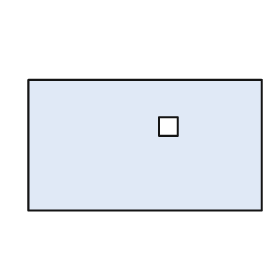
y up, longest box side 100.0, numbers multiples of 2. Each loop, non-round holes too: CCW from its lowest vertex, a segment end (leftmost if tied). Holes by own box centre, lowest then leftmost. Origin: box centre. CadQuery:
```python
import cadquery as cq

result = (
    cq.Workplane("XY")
    .moveTo(-50.0, -28.0)
    .lineTo(50.0, -28.0)
    .lineTo(50.0, 28.0)
    .lineTo(-50.0, 28.0)
    .close()
    .moveTo(6.0, 4.0)
    .lineTo(14.0, 4.0)
    .lineTo(14.0, 12.0)
    .lineTo(6.0, 12.0)
    .close()
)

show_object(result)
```